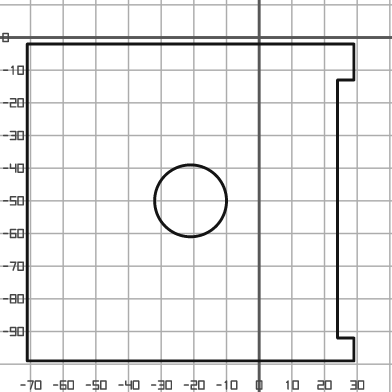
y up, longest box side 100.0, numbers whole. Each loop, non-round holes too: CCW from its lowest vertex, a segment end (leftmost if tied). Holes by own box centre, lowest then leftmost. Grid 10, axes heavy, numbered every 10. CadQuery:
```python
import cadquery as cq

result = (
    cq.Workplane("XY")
    .moveTo(-71.0, -99.0)
    .lineTo(29.0, -99.0)
    .lineTo(29.0, -92.0)
    .lineTo(24.0, -92.0)
    .lineTo(24.0, -13.0)
    .lineTo(29.0, -13.0)
    .lineTo(29.0, -2.0)
    .lineTo(-71.0, -2.0)
    .close()
    .moveTo(-21.0, -50.0)
    .circle(11.0)
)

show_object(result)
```